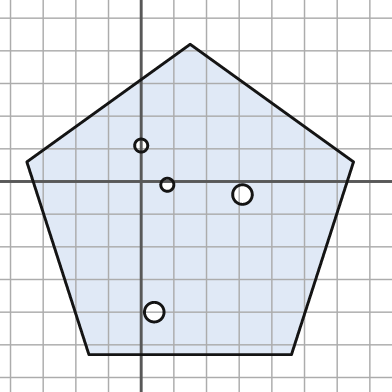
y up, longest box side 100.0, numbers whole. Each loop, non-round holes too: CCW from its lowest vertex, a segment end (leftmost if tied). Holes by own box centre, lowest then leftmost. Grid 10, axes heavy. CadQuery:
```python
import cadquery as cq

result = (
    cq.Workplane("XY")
    .moveTo(-16.0, -53.0)
    .lineTo(46.0, -53.0)
    .lineTo(65.0, 6.0)
    .lineTo(15.0, 42.0)
    .lineTo(-35.0, 6.0)
    .close()
    .moveTo(4.0, -40.0)
    .circle(3.0)
    .moveTo(31.0, -4.0)
    .circle(3.0)
    .moveTo(8.0, -1.0)
    .circle(2.0)
    .moveTo(0.0, 11.0)
    .circle(2.0)
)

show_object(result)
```